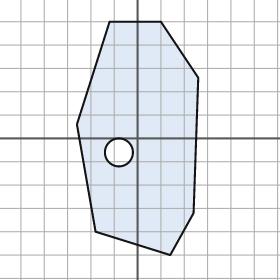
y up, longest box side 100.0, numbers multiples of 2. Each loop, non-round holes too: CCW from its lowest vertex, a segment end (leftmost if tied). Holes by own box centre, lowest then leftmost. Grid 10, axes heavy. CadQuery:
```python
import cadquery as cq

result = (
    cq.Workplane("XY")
    .moveTo(14.0, -50.0)
    .lineTo(24.0, -32.0)
    .lineTo(26.0, 26.0)
    .lineTo(10.0, 50.0)
    .lineTo(-12.0, 50.0)
    .lineTo(-26.0, 6.0)
    .lineTo(-18.0, -40.0)
    .close()
    .moveTo(-8.0, -6.0)
    .circle(6.0)
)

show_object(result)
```